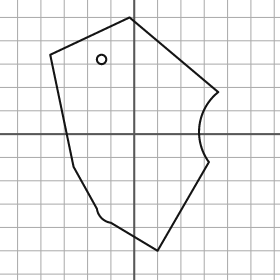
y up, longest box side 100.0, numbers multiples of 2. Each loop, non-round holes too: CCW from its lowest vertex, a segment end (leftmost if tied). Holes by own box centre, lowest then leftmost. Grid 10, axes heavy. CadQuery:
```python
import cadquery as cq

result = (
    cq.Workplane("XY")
    .moveTo(10.0, -50.0)
    .lineTo(32.0, -12.0)
    .threePointArc((28.0, 4.0), (36.0, 18.0))
    .lineTo(-2.0, 50.0)
    .lineTo(-36.0, 34.0)
    .lineTo(-26.0, -14.0)
    .lineTo(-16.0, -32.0)
    .threePointArc((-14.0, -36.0), (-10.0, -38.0))
    .close()
    .moveTo(-14.0, 32.0)
    .circle(2.0)
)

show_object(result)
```